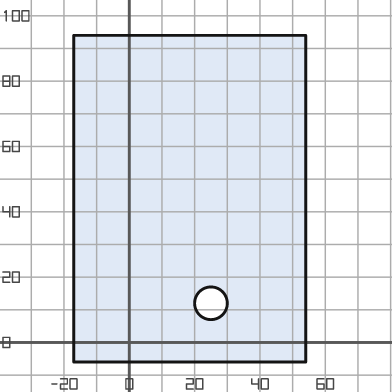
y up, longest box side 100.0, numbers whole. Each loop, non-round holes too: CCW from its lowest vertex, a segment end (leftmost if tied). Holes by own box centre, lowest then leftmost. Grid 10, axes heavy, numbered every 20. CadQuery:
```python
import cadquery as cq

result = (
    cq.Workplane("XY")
    .moveTo(-17.0, -6.0)
    .lineTo(54.0, -6.0)
    .lineTo(54.0, 94.0)
    .lineTo(-17.0, 94.0)
    .close()
    .moveTo(25.0, 12.0)
    .circle(5.0)
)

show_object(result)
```